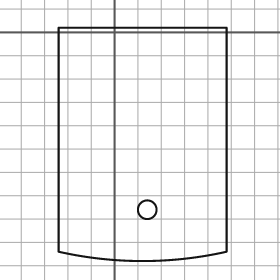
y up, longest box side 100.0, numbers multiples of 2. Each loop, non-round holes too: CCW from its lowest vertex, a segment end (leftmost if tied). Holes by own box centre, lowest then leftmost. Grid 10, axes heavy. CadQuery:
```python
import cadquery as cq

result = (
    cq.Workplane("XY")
    .moveTo(-24.0, -94.0)
    .threePointArc((12.0, -98.0), (48.0, -94.0))
    .lineTo(48.0, 2.0)
    .lineTo(-24.0, 2.0)
    .close()
    .moveTo(14.0, -76.0)
    .circle(4.0)
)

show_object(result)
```